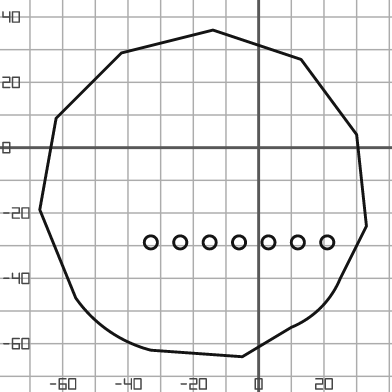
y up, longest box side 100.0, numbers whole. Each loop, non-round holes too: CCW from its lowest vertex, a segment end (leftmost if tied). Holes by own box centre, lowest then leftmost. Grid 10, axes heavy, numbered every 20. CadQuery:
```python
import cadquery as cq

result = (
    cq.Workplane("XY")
    .moveTo(-5.0, -64.0)
    .lineTo(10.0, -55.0)
    .threePointArc((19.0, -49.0), (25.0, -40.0))
    .lineTo(33.0, -24.0)
    .lineTo(30.0, 4.0)
    .lineTo(13.0, 27.0)
    .lineTo(-14.0, 36.0)
    .lineTo(-42.0, 29.0)
    .lineTo(-62.0, 9.0)
    .lineTo(-67.0, -19.0)
    .lineTo(-56.0, -46.0)
    .threePointArc((-46.0, -56.0), (-33.0, -62.0))
    .close()
    .moveTo(-33.0, -29.0)
    .circle(2.0)
    .moveTo(-24.0, -29.0)
    .circle(2.0)
    .moveTo(-15.0, -29.0)
    .circle(2.0)
    .moveTo(-6.0, -29.0)
    .circle(2.0)
    .moveTo(3.0, -29.0)
    .circle(2.0)
    .moveTo(12.0, -29.0)
    .circle(2.0)
    .moveTo(21.0, -29.0)
    .circle(2.0)
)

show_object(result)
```